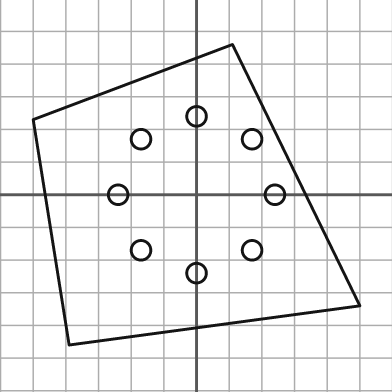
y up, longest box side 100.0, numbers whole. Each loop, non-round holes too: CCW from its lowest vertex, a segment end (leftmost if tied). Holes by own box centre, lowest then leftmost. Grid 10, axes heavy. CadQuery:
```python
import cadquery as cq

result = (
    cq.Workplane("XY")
    .moveTo(-39.0, -46.0)
    .lineTo(50.0, -34.0)
    .lineTo(11.0, 46.0)
    .lineTo(-50.0, 23.0)
    .close()
    .moveTo(0.0, -24.0)
    .circle(3.0)
    .moveTo(-17.0, -17.0)
    .circle(3.0)
    .moveTo(17.0, -17.0)
    .circle(3.0)
    .moveTo(-24.0, 0.0)
    .circle(3.0)
    .moveTo(24.0, 0.0)
    .circle(3.0)
    .moveTo(-17.0, 17.0)
    .circle(3.0)
    .moveTo(17.0, 17.0)
    .circle(3.0)
    .moveTo(0.0, 24.0)
    .circle(3.0)
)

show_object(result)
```